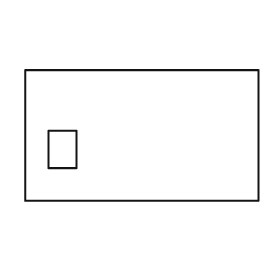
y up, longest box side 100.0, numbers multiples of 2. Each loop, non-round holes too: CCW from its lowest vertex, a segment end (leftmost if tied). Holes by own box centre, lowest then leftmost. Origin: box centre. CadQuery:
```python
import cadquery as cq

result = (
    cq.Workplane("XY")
    .moveTo(-50.0, -28.0)
    .lineTo(50.0, -28.0)
    .lineTo(50.0, 28.0)
    .lineTo(-50.0, 28.0)
    .close()
    .moveTo(-40.0, -14.0)
    .lineTo(-28.0, -14.0)
    .lineTo(-28.0, 2.0)
    .lineTo(-40.0, 2.0)
    .close()
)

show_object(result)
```